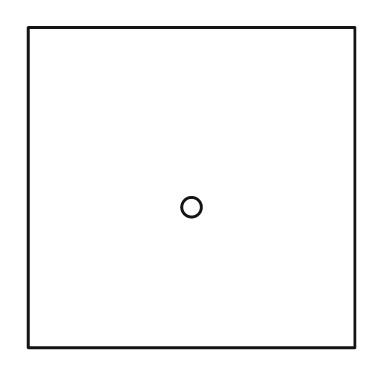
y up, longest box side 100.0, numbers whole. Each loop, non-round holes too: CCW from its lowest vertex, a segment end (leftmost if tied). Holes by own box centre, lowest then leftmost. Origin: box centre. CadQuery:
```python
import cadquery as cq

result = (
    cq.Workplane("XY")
    .moveTo(-50.0, -49.0)
    .lineTo(50.0, -49.0)
    .lineTo(50.0, 49.0)
    .lineTo(-50.0, 49.0)
    .close()
    .moveTo(0.0, -6.0)
    .circle(3.0)
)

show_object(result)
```